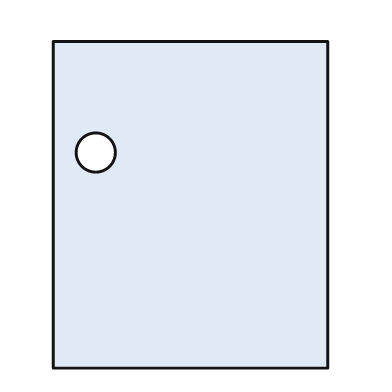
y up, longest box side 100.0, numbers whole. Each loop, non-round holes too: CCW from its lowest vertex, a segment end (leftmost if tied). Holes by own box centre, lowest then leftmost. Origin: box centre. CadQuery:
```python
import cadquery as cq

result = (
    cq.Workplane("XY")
    .moveTo(-42.0, -50.0)
    .lineTo(42.0, -50.0)
    .lineTo(42.0, 50.0)
    .lineTo(-42.0, 50.0)
    .close()
    .moveTo(-29.0, 16.0)
    .circle(6.0)
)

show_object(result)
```